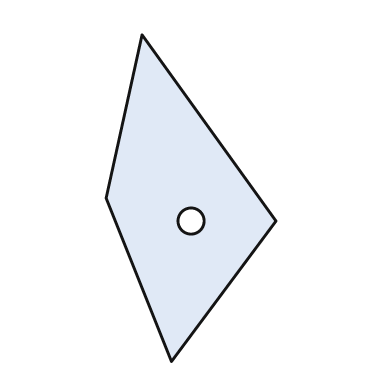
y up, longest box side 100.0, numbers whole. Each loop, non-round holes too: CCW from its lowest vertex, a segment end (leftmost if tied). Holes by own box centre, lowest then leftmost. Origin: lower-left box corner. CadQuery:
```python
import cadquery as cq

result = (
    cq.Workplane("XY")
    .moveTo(20.0, 0.0)
    .lineTo(52.0, 43.0)
    .lineTo(11.0, 100.0)
    .lineTo(0.0, 50.0)
    .close()
    .moveTo(26.0, 43.0)
    .circle(4.0)
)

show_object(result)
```